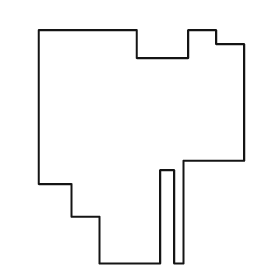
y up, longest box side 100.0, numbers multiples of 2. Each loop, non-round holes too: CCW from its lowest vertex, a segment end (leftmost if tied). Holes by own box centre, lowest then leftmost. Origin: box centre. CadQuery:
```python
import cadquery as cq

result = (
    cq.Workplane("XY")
    .moveTo(-18.0, -50.0)
    .lineTo(8.0, -50.0)
    .lineTo(8.0, -10.0)
    .lineTo(14.0, -10.0)
    .lineTo(14.0, -50.0)
    .lineTo(18.0, -50.0)
    .lineTo(18.0, -6.0)
    .lineTo(44.0, -6.0)
    .lineTo(44.0, 44.0)
    .lineTo(32.0, 44.0)
    .lineTo(32.0, 50.0)
    .lineTo(20.0, 50.0)
    .lineTo(20.0, 38.0)
    .lineTo(-2.0, 38.0)
    .lineTo(-2.0, 50.0)
    .lineTo(-44.0, 50.0)
    .lineTo(-44.0, -16.0)
    .lineTo(-30.0, -16.0)
    .lineTo(-30.0, -30.0)
    .lineTo(-18.0, -30.0)
    .close()
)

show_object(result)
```